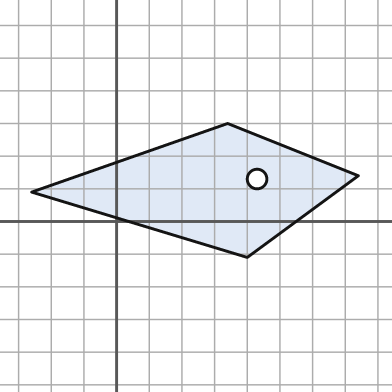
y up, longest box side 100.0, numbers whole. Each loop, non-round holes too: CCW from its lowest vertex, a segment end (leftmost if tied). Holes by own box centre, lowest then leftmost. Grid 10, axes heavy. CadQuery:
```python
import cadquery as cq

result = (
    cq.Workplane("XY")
    .moveTo(40.0, -11.0)
    .lineTo(74.0, 14.0)
    .lineTo(34.0, 30.0)
    .lineTo(-26.0, 9.0)
    .close()
    .moveTo(43.0, 13.0)
    .circle(3.0)
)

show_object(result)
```